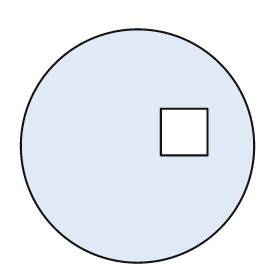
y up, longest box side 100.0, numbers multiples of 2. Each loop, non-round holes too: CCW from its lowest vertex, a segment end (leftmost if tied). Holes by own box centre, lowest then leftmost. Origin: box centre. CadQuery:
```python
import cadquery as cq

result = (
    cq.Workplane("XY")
    .moveTo(0.0, 0.0)
    .circle(50.0)
    .moveTo(10.0, -4.0)
    .lineTo(30.0, -4.0)
    .lineTo(30.0, 16.0)
    .lineTo(10.0, 16.0)
    .close()
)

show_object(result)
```